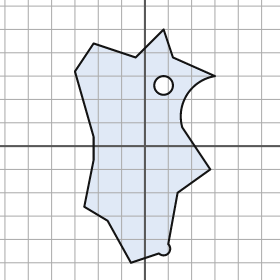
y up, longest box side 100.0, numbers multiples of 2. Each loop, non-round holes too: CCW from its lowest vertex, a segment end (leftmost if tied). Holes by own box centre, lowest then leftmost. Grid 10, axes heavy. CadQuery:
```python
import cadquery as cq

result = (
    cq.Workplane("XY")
    .moveTo(-6.0, -50.0)
    .lineTo(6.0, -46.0)
    .threePointArc((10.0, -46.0), (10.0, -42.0))
    .lineTo(14.0, -20.0)
    .lineTo(28.0, -10.0)
    .lineTo(16.0, 8.0)
    .threePointArc((18.0, 22.0), (30.0, 30.0))
    .lineTo(12.0, 38.0)
    .lineTo(8.0, 50.0)
    .lineTo(-4.0, 38.0)
    .lineTo(-22.0, 44.0)
    .lineTo(-30.0, 32.0)
    .lineTo(-22.0, 4.0)
    .lineTo(-22.0, -6.0)
    .lineTo(-26.0, -26.0)
    .lineTo(-16.0, -32.0)
    .close()
    .moveTo(8.0, 26.0)
    .circle(4.0)
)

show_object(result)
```